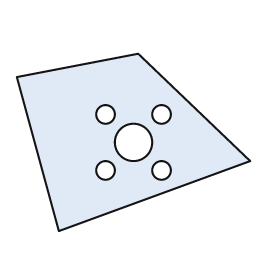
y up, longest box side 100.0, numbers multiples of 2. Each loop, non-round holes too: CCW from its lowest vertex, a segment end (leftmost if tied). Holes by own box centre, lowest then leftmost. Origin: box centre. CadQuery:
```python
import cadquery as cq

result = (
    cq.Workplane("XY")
    .moveTo(-32.0, -38.0)
    .lineTo(50.0, -8.0)
    .lineTo(2.0, 38.0)
    .lineTo(-50.0, 28.0)
    .close()
    .moveTo(-12.0, -12.0)
    .circle(4.0)
    .moveTo(12.0, -12.0)
    .circle(4.0)
    .moveTo(0.0, 0.0)
    .circle(8.0)
    .moveTo(-12.0, 12.0)
    .circle(4.0)
    .moveTo(12.0, 12.0)
    .circle(4.0)
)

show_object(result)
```